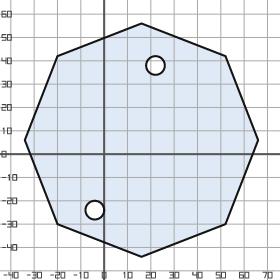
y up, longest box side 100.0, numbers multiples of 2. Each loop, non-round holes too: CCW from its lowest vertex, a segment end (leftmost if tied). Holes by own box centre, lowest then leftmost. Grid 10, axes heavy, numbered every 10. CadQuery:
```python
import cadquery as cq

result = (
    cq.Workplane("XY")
    .moveTo(16.0, -44.0)
    .lineTo(52.0, -30.0)
    .lineTo(66.0, 6.0)
    .lineTo(52.0, 42.0)
    .lineTo(16.0, 56.0)
    .lineTo(-20.0, 42.0)
    .lineTo(-34.0, 6.0)
    .lineTo(-20.0, -30.0)
    .close()
    .moveTo(-4.0, -24.0)
    .circle(4.0)
    .moveTo(22.0, 38.0)
    .circle(4.0)
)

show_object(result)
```